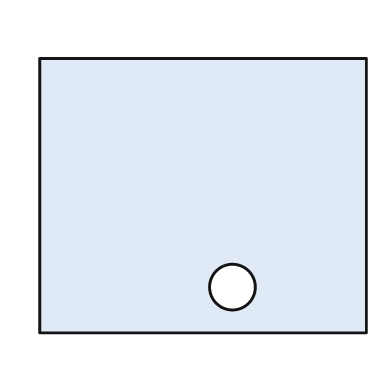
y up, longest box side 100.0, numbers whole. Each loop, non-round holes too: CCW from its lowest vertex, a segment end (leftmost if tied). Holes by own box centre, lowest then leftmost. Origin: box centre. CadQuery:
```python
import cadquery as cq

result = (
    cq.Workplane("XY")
    .moveTo(-50.0, -42.0)
    .lineTo(50.0, -42.0)
    .lineTo(50.0, 42.0)
    .lineTo(-50.0, 42.0)
    .close()
    .moveTo(9.0, -28.0)
    .circle(7.0)
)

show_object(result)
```